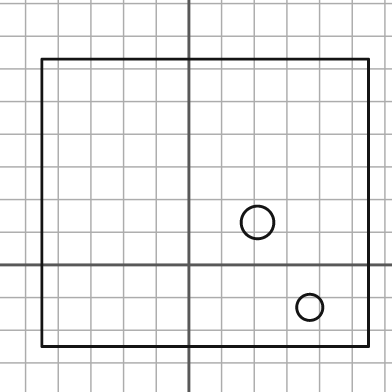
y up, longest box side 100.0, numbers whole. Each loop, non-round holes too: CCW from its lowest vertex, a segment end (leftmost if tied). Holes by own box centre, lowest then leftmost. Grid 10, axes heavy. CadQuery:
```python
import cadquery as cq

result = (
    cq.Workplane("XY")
    .moveTo(-45.0, -25.0)
    .lineTo(55.0, -25.0)
    .lineTo(55.0, 63.0)
    .lineTo(-45.0, 63.0)
    .close()
    .moveTo(37.0, -13.0)
    .circle(4.0)
    .moveTo(21.0, 13.0)
    .circle(5.0)
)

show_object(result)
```